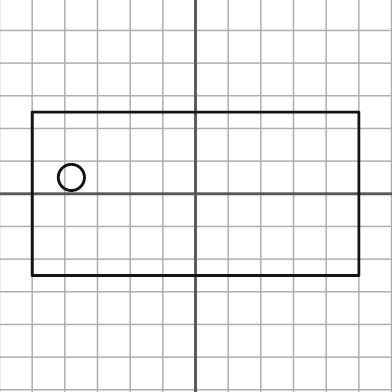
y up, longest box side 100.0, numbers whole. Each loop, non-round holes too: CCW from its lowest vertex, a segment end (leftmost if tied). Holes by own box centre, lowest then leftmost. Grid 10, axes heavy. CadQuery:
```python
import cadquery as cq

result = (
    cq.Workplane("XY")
    .moveTo(-50.0, -25.0)
    .lineTo(50.0, -25.0)
    .lineTo(50.0, 25.0)
    .lineTo(-50.0, 25.0)
    .close()
    .moveTo(-38.0, 5.0)
    .circle(4.0)
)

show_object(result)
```